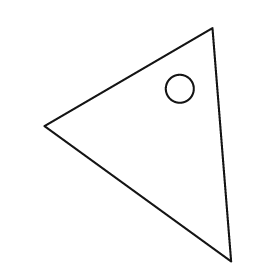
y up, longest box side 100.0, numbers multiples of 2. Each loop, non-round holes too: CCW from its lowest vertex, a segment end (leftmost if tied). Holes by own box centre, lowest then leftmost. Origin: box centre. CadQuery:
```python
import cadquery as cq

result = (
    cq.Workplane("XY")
    .moveTo(40.0, -50.0)
    .lineTo(32.0, 50.0)
    .lineTo(-40.0, 8.0)
    .close()
    .moveTo(18.0, 24.0)
    .circle(6.0)
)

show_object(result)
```